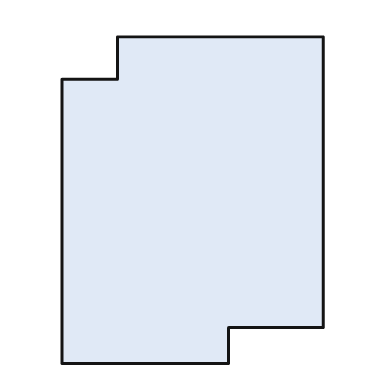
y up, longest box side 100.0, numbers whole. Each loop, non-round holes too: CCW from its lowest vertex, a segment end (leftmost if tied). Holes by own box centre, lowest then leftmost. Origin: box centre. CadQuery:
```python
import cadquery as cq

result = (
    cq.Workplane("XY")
    .moveTo(-40.0, -50.0)
    .lineTo(11.0, -50.0)
    .lineTo(11.0, -39.0)
    .lineTo(40.0, -39.0)
    .lineTo(40.0, 50.0)
    .lineTo(-23.0, 50.0)
    .lineTo(-23.0, 37.0)
    .lineTo(-40.0, 37.0)
    .close()
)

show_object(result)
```